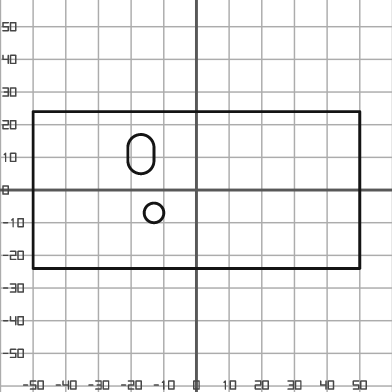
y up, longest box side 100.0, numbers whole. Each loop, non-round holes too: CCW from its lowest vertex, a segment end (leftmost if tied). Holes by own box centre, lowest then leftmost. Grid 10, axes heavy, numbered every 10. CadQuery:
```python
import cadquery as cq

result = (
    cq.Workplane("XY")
    .moveTo(-50.0, -24.0)
    .lineTo(50.0, -24.0)
    .lineTo(50.0, 24.0)
    .lineTo(-50.0, 24.0)
    .close()
    .moveTo(-13.0, -7.0)
    .circle(3.0)
    .moveTo(-21.0, 9.0)
    .threePointArc((-17.0, 5.0), (-13.0, 9.0))
    .lineTo(-13.0, 13.0)
    .threePointArc((-17.0, 17.0), (-21.0, 13.0))
    .close()
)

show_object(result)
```